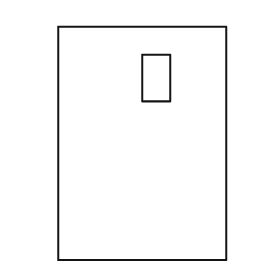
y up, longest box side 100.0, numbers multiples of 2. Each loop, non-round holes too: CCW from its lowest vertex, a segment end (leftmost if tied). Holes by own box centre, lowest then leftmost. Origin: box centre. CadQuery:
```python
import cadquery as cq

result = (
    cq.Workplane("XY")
    .moveTo(-36.0, -50.0)
    .lineTo(36.0, -50.0)
    .lineTo(36.0, 50.0)
    .lineTo(-36.0, 50.0)
    .close()
    .moveTo(0.0, 18.0)
    .lineTo(12.0, 18.0)
    .lineTo(12.0, 38.0)
    .lineTo(0.0, 38.0)
    .close()
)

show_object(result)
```